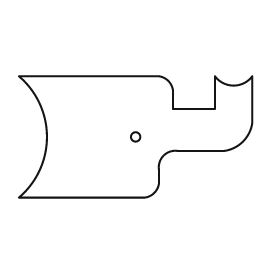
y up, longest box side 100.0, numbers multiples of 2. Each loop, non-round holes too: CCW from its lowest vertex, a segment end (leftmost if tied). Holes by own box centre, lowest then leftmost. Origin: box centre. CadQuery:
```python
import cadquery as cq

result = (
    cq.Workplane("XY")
    .moveTo(-50.0, -26.0)
    .lineTo(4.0, -26.0)
    .threePointArc((8.0, -24.0), (10.0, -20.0))
    .lineTo(10.0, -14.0)
    .threePointArc((12.0, -8.0), (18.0, -6.0))
    .lineTo(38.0, -6.0)
    .threePointArc((46.0, -2.0), (50.0, 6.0))
    .lineTo(50.0, 26.0)
    .threePointArc((42.0, 22.0), (34.0, 26.0))
    .lineTo(34.0, 12.0)
    .lineTo(16.0, 12.0)
    .lineTo(16.0, 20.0)
    .threePointArc((14.0, 24.0), (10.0, 26.0))
    .lineTo(-50.0, 26.0)
    .threePointArc((-38.0, 0.0), (-50.0, -26.0))
    .close()
    .moveTo(0.0, 0.0)
    .circle(2.0)
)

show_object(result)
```